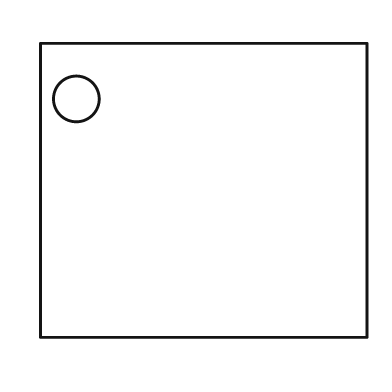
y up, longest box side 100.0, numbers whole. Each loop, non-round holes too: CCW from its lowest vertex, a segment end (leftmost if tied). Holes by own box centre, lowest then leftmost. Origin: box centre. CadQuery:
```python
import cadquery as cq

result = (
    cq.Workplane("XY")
    .moveTo(-50.0, -45.0)
    .lineTo(50.0, -45.0)
    .lineTo(50.0, 45.0)
    .lineTo(-50.0, 45.0)
    .close()
    .moveTo(-39.0, 28.0)
    .circle(7.0)
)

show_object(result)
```